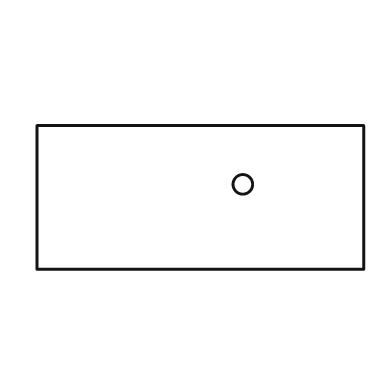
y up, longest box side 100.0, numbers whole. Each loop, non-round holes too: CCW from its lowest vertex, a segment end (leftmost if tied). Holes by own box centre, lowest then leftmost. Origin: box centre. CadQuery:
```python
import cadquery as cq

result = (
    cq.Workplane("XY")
    .moveTo(-50.0, -22.0)
    .lineTo(50.0, -22.0)
    .lineTo(50.0, 22.0)
    .lineTo(-50.0, 22.0)
    .close()
    .moveTo(13.0, 4.0)
    .circle(3.0)
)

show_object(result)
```